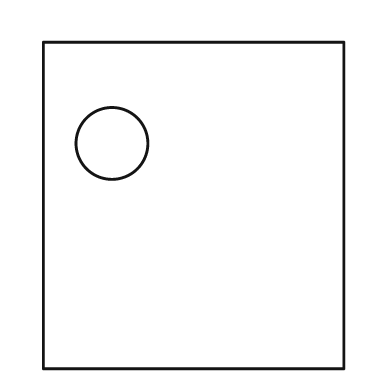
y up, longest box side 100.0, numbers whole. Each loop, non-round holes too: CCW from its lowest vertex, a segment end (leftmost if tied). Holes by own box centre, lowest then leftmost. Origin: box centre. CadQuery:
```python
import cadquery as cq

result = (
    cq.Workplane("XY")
    .moveTo(-46.0, -50.0)
    .lineTo(46.0, -50.0)
    .lineTo(46.0, 50.0)
    .lineTo(-46.0, 50.0)
    .close()
    .moveTo(-25.0, 19.0)
    .circle(11.0)
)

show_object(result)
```